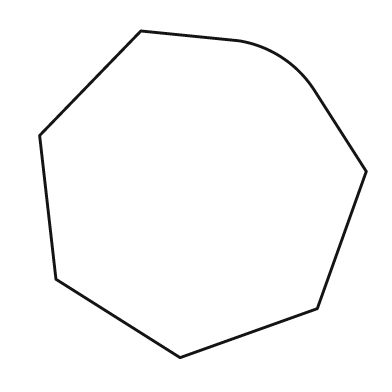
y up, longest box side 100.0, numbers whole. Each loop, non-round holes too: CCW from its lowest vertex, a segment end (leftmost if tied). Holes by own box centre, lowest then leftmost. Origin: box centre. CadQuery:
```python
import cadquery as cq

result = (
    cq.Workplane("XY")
    .moveTo(-7.0, -50.0)
    .lineTo(35.0, -35.0)
    .lineTo(50.0, 7.0)
    .lineTo(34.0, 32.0)
    .threePointArc((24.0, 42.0), (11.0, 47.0))
    .lineTo(-19.0, 50.0)
    .lineTo(-50.0, 18.0)
    .lineTo(-45.0, -26.0)
    .close()
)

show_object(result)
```